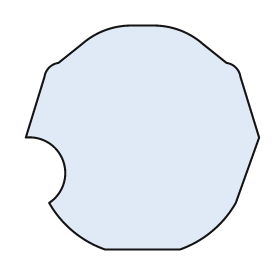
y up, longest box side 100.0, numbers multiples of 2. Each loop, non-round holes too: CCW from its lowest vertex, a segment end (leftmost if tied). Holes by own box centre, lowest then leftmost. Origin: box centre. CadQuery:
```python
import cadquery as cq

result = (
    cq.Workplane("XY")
    .moveTo(-16.0, -48.0)
    .lineTo(16.0, -48.0)
    .threePointArc((30.0, -40.0), (40.0, -28.0))
    .lineTo(50.0, 0.0)
    .lineTo(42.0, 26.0)
    .threePointArc((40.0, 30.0), (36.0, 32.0))
    .lineTo(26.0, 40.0)
    .threePointArc((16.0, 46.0), (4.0, 48.0))
    .lineTo(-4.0, 48.0)
    .threePointArc((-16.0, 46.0), (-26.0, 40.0))
    .lineTo(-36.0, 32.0)
    .threePointArc((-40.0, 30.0), (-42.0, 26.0))
    .lineTo(-50.0, 0.0)
    .threePointArc((-34.0, -10.0), (-40.0, -28.0))
    .threePointArc((-30.0, -40.0), (-16.0, -48.0))
    .close()
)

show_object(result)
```